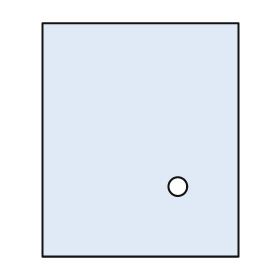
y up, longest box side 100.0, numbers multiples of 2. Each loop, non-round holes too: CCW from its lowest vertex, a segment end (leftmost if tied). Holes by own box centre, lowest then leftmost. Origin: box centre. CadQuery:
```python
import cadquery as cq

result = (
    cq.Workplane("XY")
    .moveTo(-42.0, -50.0)
    .lineTo(42.0, -50.0)
    .lineTo(42.0, 50.0)
    .lineTo(-42.0, 50.0)
    .close()
    .moveTo(16.0, -20.0)
    .circle(4.0)
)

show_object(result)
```